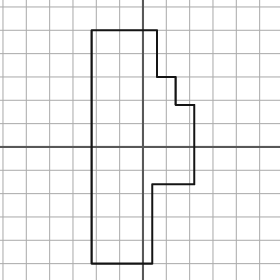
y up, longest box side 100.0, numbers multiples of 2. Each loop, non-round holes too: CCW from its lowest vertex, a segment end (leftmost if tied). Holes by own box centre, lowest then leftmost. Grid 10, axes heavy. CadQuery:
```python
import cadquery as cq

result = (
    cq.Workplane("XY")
    .moveTo(-22.0, -50.0)
    .lineTo(4.0, -50.0)
    .lineTo(4.0, -16.0)
    .lineTo(22.0, -16.0)
    .lineTo(22.0, 18.0)
    .lineTo(14.0, 18.0)
    .lineTo(14.0, 30.0)
    .lineTo(6.0, 30.0)
    .lineTo(6.0, 50.0)
    .lineTo(-22.0, 50.0)
    .close()
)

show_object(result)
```